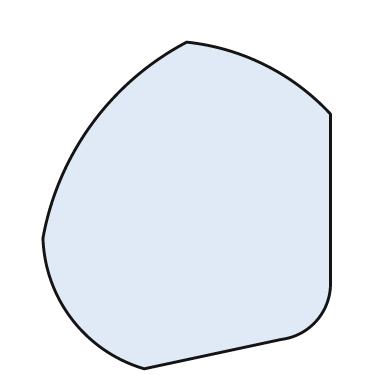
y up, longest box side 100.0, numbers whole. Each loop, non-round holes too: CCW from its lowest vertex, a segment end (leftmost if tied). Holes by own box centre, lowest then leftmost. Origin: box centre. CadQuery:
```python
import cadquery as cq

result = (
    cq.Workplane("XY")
    .moveTo(-13.0, -50.0)
    .lineTo(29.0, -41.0)
    .threePointArc((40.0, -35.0), (44.0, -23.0))
    .lineTo(44.0, 28.0)
    .threePointArc((24.0, 43.0), (0.0, 50.0))
    .threePointArc((-29.0, 25.0), (-44.0, -10.0))
    .threePointArc((-35.0, -35.0), (-13.0, -50.0))
    .close()
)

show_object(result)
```